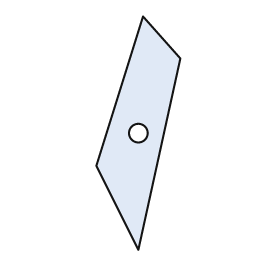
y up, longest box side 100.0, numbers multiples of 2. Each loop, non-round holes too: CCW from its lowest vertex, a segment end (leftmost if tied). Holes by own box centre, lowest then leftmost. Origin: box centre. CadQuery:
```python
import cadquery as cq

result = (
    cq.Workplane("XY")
    .moveTo(0.0, -50.0)
    .lineTo(18.0, 32.0)
    .lineTo(2.0, 50.0)
    .lineTo(-18.0, -14.0)
    .close()
    .moveTo(0.0, 0.0)
    .circle(4.0)
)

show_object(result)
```